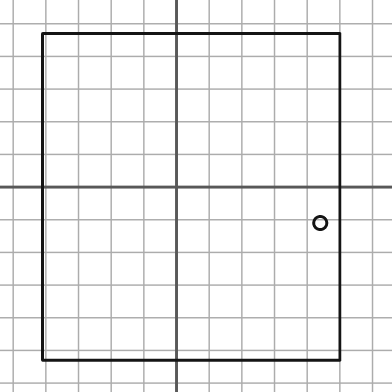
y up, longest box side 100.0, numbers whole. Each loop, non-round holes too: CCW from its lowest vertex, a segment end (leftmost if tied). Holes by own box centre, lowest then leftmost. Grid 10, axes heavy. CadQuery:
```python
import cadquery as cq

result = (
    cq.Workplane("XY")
    .moveTo(-41.0, -53.0)
    .lineTo(50.0, -53.0)
    .lineTo(50.0, 47.0)
    .lineTo(-41.0, 47.0)
    .close()
    .moveTo(44.0, -11.0)
    .circle(2.0)
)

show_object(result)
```